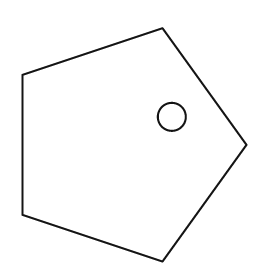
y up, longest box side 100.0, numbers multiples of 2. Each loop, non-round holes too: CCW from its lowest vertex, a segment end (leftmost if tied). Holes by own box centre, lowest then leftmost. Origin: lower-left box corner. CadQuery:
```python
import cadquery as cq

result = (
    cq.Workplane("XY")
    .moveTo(60.0, 0.0)
    .lineTo(96.0, 50.0)
    .lineTo(60.0, 100.0)
    .lineTo(0.0, 80.0)
    .lineTo(0.0, 20.0)
    .close()
    .moveTo(64.0, 62.0)
    .circle(6.0)
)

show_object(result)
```